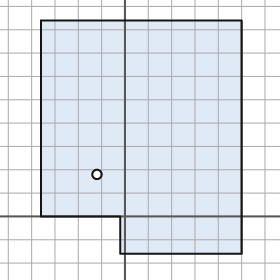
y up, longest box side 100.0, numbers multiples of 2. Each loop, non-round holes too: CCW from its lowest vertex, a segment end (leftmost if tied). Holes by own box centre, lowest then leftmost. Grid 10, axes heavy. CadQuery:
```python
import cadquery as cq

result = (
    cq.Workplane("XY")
    .moveTo(-2.0, -16.0)
    .lineTo(50.0, -16.0)
    .lineTo(50.0, 84.0)
    .lineTo(-36.0, 84.0)
    .lineTo(-36.0, 0.0)
    .lineTo(-2.0, 0.0)
    .close()
    .moveTo(-12.0, 18.0)
    .circle(2.0)
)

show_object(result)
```